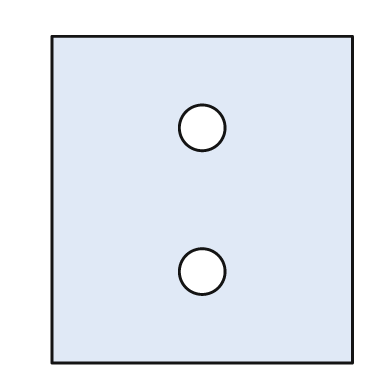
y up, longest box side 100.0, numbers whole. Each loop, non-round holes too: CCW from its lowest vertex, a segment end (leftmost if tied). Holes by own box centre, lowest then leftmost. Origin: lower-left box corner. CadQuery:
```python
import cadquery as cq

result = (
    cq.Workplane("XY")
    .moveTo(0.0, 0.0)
    .lineTo(92.0, 0.0)
    .lineTo(92.0, 100.0)
    .lineTo(0.0, 100.0)
    .close()
    .moveTo(46.0, 28.0)
    .circle(7.0)
    .moveTo(46.0, 72.0)
    .circle(7.0)
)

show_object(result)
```